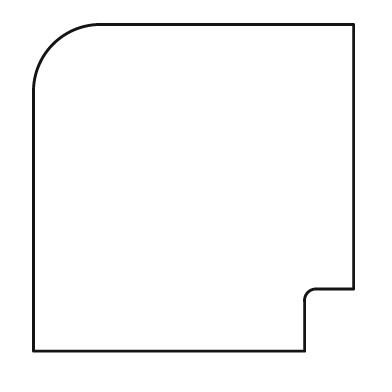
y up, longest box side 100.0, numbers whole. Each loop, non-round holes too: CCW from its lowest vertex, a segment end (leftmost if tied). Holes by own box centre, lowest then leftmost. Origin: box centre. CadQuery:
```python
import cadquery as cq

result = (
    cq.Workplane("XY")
    .moveTo(-49.0, -50.0)
    .lineTo(34.0, -50.0)
    .lineTo(34.0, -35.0)
    .threePointArc((35.0, -32.0), (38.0, -31.0))
    .lineTo(49.0, -31.0)
    .lineTo(49.0, 50.0)
    .lineTo(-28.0, 50.0)
    .threePointArc((-43.0, 44.0), (-49.0, 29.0))
    .close()
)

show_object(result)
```